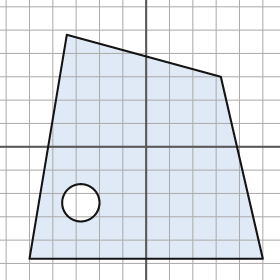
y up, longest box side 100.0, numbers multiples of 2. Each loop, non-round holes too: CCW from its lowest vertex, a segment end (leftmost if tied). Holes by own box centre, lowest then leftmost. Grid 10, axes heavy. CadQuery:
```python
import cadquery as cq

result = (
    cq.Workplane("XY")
    .moveTo(-50.0, -48.0)
    .lineTo(50.0, -48.0)
    .lineTo(32.0, 30.0)
    .lineTo(-34.0, 48.0)
    .close()
    .moveTo(-28.0, -24.0)
    .circle(8.0)
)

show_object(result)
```